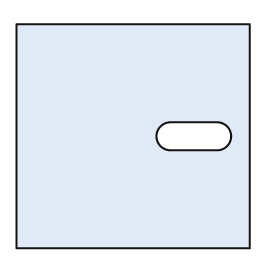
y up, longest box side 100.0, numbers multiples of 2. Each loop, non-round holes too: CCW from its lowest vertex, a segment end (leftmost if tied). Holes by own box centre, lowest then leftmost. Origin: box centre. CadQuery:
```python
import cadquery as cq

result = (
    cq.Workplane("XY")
    .moveTo(-50.0, -48.0)
    .lineTo(50.0, -48.0)
    .lineTo(50.0, 48.0)
    .lineTo(-50.0, 48.0)
    .close()
    .moveTo(16.0, -6.0)
    .lineTo(36.0, -6.0)
    .threePointArc((42.0, 0.0), (36.0, 6.0))
    .lineTo(16.0, 6.0)
    .threePointArc((10.0, 0.0), (16.0, -6.0))
    .close()
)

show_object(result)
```